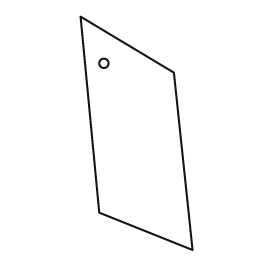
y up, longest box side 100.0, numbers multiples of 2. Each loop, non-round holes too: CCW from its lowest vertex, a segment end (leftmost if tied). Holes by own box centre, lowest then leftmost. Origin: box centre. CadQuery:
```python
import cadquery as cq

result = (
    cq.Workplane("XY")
    .moveTo(24.0, -50.0)
    .lineTo(16.0, 26.0)
    .lineTo(-24.0, 50.0)
    .lineTo(-16.0, -34.0)
    .close()
    .moveTo(-14.0, 30.0)
    .circle(2.0)
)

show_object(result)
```